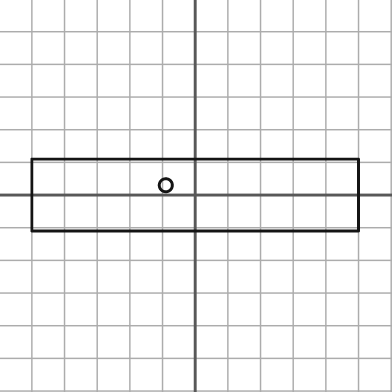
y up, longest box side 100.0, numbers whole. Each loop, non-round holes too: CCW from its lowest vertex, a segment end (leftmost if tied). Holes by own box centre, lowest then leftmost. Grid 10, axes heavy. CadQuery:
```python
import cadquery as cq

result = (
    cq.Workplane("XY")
    .moveTo(-50.0, -11.0)
    .lineTo(50.0, -11.0)
    .lineTo(50.0, 11.0)
    .lineTo(-50.0, 11.0)
    .close()
    .moveTo(-9.0, 3.0)
    .circle(2.0)
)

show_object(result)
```